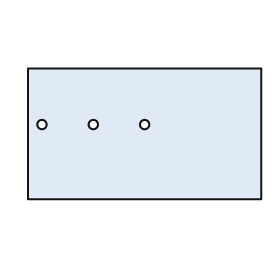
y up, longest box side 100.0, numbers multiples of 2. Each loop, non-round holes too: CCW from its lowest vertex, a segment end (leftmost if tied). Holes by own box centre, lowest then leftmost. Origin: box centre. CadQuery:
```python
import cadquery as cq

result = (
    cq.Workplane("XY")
    .moveTo(-50.0, -28.0)
    .lineTo(50.0, -28.0)
    .lineTo(50.0, 28.0)
    .lineTo(-50.0, 28.0)
    .close()
    .moveTo(-44.0, 4.0)
    .circle(2.0)
    .moveTo(-22.0, 4.0)
    .circle(2.0)
    .moveTo(0.0, 4.0)
    .circle(2.0)
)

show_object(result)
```